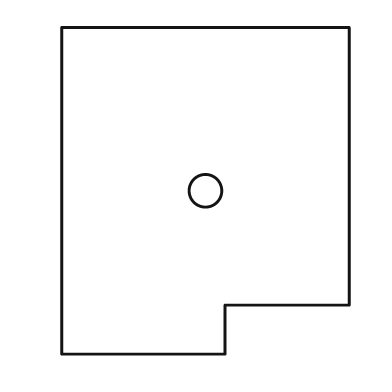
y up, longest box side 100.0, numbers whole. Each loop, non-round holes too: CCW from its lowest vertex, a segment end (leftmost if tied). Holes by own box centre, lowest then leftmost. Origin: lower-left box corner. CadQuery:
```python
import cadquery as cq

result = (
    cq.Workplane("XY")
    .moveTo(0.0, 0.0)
    .lineTo(50.0, 0.0)
    .lineTo(50.0, 15.0)
    .lineTo(88.0, 15.0)
    .lineTo(88.0, 100.0)
    .lineTo(0.0, 100.0)
    .close()
    .moveTo(44.0, 50.0)
    .circle(5.0)
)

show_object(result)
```